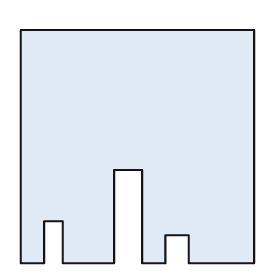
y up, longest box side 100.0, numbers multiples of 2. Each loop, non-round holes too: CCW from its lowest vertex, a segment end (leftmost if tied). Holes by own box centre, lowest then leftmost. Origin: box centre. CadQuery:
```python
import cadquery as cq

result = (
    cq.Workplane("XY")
    .moveTo(-50.0, -50.0)
    .lineTo(-40.0, -50.0)
    .lineTo(-40.0, -32.0)
    .lineTo(-32.0, -32.0)
    .lineTo(-32.0, -50.0)
    .lineTo(-10.0, -50.0)
    .lineTo(-10.0, -10.0)
    .lineTo(2.0, -10.0)
    .lineTo(2.0, -50.0)
    .lineTo(12.0, -50.0)
    .lineTo(12.0, -38.0)
    .lineTo(22.0, -38.0)
    .lineTo(22.0, -50.0)
    .lineTo(50.0, -50.0)
    .lineTo(50.0, 50.0)
    .lineTo(-50.0, 50.0)
    .close()
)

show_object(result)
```